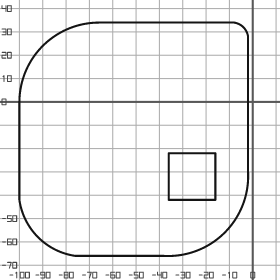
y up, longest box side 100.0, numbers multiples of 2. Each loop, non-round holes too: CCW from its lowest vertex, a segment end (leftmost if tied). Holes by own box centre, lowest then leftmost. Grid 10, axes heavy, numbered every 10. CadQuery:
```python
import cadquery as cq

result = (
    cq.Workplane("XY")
    .moveTo(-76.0, -66.0)
    .lineTo(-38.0, -66.0)
    .threePointArc((-12.0, -56.0), (-2.0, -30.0))
    .lineTo(-2.0, 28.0)
    .threePointArc((-4.0, 32.0), (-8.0, 34.0))
    .lineTo(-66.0, 34.0)
    .threePointArc((-90.0, 24.0), (-100.0, 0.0))
    .lineTo(-100.0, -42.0)
    .threePointArc((-92.0, -58.0), (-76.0, -66.0))
    .close()
    .moveTo(-36.0, -42.0)
    .lineTo(-16.0, -42.0)
    .lineTo(-16.0, -22.0)
    .lineTo(-36.0, -22.0)
    .close()
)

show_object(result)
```